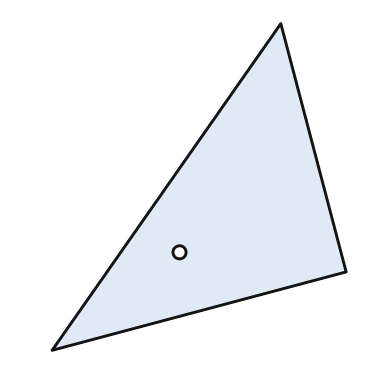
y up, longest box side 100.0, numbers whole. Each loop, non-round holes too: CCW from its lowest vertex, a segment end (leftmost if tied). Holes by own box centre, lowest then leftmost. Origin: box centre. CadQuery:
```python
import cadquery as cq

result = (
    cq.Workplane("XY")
    .moveTo(-45.0, -50.0)
    .lineTo(45.0, -26.0)
    .lineTo(25.0, 50.0)
    .close()
    .moveTo(-6.0, -20.0)
    .circle(2.0)
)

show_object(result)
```